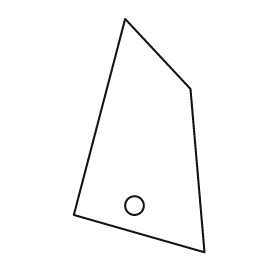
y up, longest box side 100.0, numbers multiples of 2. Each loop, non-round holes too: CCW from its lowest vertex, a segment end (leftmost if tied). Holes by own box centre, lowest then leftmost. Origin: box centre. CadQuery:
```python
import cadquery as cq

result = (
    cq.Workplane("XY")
    .moveTo(28.0, -50.0)
    .lineTo(22.0, 20.0)
    .lineTo(-6.0, 50.0)
    .lineTo(-28.0, -34.0)
    .close()
    .moveTo(-2.0, -30.0)
    .circle(4.0)
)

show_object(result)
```